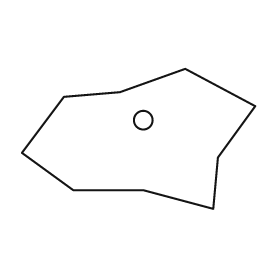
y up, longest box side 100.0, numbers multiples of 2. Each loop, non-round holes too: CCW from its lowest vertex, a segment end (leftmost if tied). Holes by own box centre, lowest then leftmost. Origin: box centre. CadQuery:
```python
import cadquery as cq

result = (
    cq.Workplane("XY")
    .moveTo(32.0, -30.0)
    .lineTo(34.0, -8.0)
    .lineTo(50.0, 14.0)
    .lineTo(20.0, 30.0)
    .lineTo(-8.0, 20.0)
    .lineTo(-32.0, 18.0)
    .lineTo(-50.0, -6.0)
    .lineTo(-28.0, -22.0)
    .lineTo(2.0, -22.0)
    .close()
    .moveTo(2.0, 8.0)
    .circle(4.0)
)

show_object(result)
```